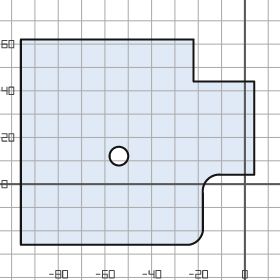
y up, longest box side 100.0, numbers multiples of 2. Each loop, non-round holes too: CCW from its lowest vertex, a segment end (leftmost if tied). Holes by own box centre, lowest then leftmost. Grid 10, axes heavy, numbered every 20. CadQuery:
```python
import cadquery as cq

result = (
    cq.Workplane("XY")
    .moveTo(-96.0, -26.0)
    .lineTo(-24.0, -26.0)
    .threePointArc((-20.0, -24.0), (-18.0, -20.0))
    .lineTo(-18.0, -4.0)
    .threePointArc((-16.0, 2.0), (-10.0, 4.0))
    .lineTo(4.0, 4.0)
    .lineTo(4.0, 44.0)
    .lineTo(-22.0, 44.0)
    .lineTo(-22.0, 62.0)
    .lineTo(-96.0, 62.0)
    .close()
    .moveTo(-54.0, 12.0)
    .circle(4.0)
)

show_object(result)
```